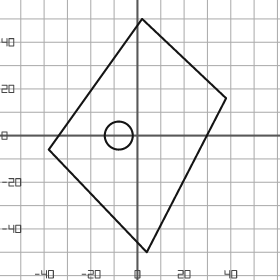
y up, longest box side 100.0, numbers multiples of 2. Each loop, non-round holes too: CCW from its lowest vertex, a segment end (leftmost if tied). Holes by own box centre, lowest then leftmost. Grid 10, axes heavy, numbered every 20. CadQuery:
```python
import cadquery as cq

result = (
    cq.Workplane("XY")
    .moveTo(4.0, -50.0)
    .lineTo(38.0, 16.0)
    .lineTo(2.0, 50.0)
    .lineTo(-38.0, -6.0)
    .close()
    .moveTo(-8.0, 0.0)
    .circle(6.0)
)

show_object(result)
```